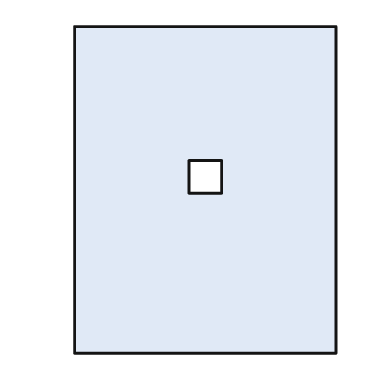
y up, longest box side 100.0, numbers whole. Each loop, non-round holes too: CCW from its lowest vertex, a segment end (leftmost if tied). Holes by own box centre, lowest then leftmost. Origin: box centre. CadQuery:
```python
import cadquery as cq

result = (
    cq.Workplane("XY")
    .moveTo(-40.0, -50.0)
    .lineTo(40.0, -50.0)
    .lineTo(40.0, 50.0)
    .lineTo(-40.0, 50.0)
    .close()
    .moveTo(-5.0, -1.0)
    .lineTo(5.0, -1.0)
    .lineTo(5.0, 9.0)
    .lineTo(-5.0, 9.0)
    .close()
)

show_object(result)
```